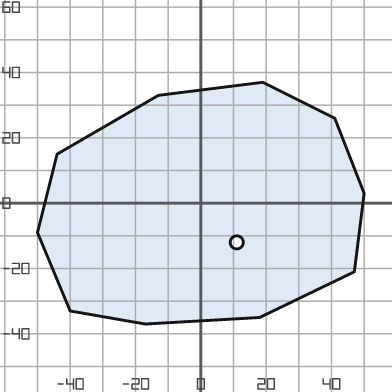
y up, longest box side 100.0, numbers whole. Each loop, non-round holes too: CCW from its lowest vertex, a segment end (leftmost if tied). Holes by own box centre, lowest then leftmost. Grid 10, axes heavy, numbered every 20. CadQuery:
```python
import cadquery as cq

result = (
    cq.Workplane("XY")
    .moveTo(-17.0, -37.0)
    .lineTo(18.0, -35.0)
    .lineTo(47.0, -21.0)
    .lineTo(50.0, 3.0)
    .lineTo(41.0, 26.0)
    .lineTo(19.0, 37.0)
    .lineTo(-13.0, 33.0)
    .lineTo(-44.0, 15.0)
    .lineTo(-50.0, -9.0)
    .lineTo(-40.0, -33.0)
    .close()
    .moveTo(11.0, -12.0)
    .circle(2.0)
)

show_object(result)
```